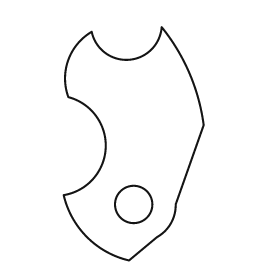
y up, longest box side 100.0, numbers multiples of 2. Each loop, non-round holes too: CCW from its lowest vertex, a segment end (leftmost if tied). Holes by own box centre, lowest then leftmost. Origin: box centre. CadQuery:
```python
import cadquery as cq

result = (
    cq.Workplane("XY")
    .moveTo(-2.0, -50.0)
    .lineTo(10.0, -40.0)
    .threePointArc((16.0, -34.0), (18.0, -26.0))
    .lineTo(30.0, 8.0)
    .threePointArc((24.0, 30.0), (12.0, 50.0))
    .threePointArc((-2.0, 36.0), (-18.0, 48.0))
    .threePointArc((-28.0, 36.0), (-28.0, 20.0))
    .threePointArc((-12.0, -2.0), (-30.0, -22.0))
    .threePointArc((-20.0, -40.0), (-2.0, -50.0))
    .close()
    .moveTo(0.0, -26.0)
    .circle(8.0)
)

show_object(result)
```